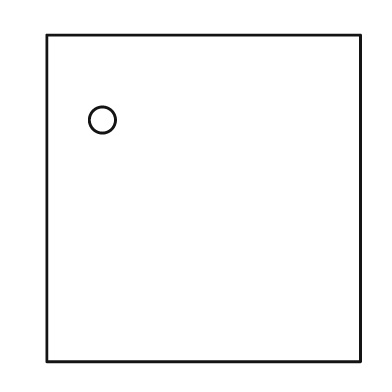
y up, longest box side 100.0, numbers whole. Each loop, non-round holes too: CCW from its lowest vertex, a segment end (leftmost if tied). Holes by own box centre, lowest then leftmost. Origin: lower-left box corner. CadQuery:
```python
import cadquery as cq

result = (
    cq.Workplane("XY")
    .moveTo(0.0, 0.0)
    .lineTo(96.0, 0.0)
    .lineTo(96.0, 100.0)
    .lineTo(0.0, 100.0)
    .close()
    .moveTo(17.0, 74.0)
    .circle(4.0)
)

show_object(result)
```